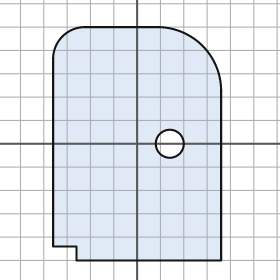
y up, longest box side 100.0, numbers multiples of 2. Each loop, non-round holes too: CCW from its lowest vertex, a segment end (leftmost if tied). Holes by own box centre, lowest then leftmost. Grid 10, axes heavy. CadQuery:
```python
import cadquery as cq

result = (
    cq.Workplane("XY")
    .moveTo(-26.0, -50.0)
    .lineTo(36.0, -50.0)
    .lineTo(36.0, 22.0)
    .threePointArc((28.0, 42.0), (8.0, 50.0))
    .lineTo(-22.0, 50.0)
    .threePointArc((-32.0, 46.0), (-36.0, 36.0))
    .lineTo(-36.0, -44.0)
    .lineTo(-26.0, -44.0)
    .close()
    .moveTo(14.0, 0.0)
    .circle(6.0)
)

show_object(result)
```